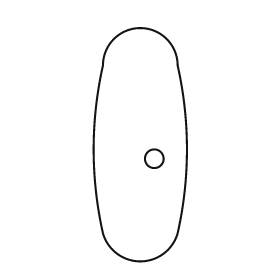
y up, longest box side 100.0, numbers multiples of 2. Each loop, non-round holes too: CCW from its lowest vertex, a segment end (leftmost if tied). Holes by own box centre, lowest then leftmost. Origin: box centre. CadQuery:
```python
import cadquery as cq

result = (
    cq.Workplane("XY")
    .moveTo(-16.0, -38.0)
    .threePointArc((0.0, -50.0), (16.0, -38.0))
    .threePointArc((20.0, -2.0), (16.0, 34.0))
    .threePointArc((0.0, 50.0), (-16.0, 34.0))
    .threePointArc((-20.0, -2.0), (-16.0, -38.0))
    .close()
    .moveTo(6.0, -6.0)
    .circle(4.0)
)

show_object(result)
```